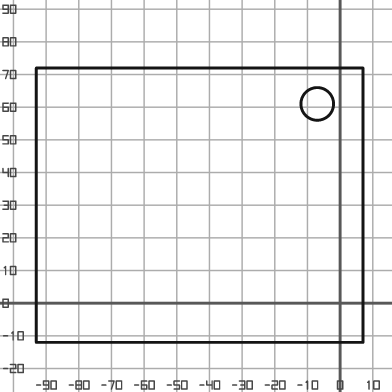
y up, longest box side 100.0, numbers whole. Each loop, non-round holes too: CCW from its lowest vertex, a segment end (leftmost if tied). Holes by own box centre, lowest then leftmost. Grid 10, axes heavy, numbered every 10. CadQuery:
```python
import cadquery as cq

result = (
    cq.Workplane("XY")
    .moveTo(-93.0, -12.0)
    .lineTo(7.0, -12.0)
    .lineTo(7.0, 72.0)
    .lineTo(-93.0, 72.0)
    .close()
    .moveTo(-7.0, 61.0)
    .circle(5.0)
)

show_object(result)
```